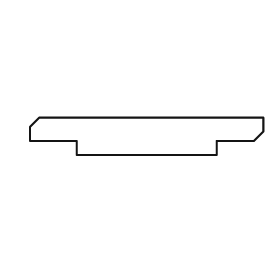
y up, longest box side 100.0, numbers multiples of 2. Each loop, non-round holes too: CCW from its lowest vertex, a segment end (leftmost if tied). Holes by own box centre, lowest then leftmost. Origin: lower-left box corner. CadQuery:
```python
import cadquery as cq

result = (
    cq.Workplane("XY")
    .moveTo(20.0, 0.0)
    .lineTo(80.0, 0.0)
    .lineTo(80.0, 6.0)
    .lineTo(96.0, 6.0)
    .lineTo(100.0, 10.0)
    .lineTo(100.0, 16.0)
    .lineTo(4.0, 16.0)
    .lineTo(0.0, 12.0)
    .lineTo(0.0, 6.0)
    .lineTo(20.0, 6.0)
    .close()
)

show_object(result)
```